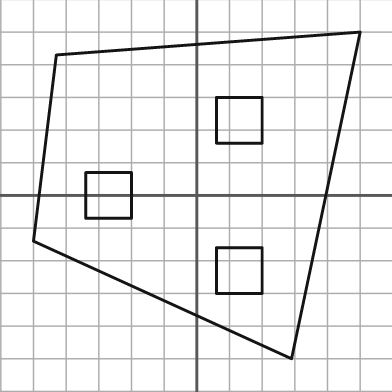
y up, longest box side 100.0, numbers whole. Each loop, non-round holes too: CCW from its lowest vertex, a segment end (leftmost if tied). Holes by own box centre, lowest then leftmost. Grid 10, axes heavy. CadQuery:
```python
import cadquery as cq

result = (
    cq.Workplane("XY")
    .moveTo(29.0, -50.0)
    .lineTo(50.0, 50.0)
    .lineTo(-43.0, 43.0)
    .lineTo(-50.0, -14.0)
    .close()
    .moveTo(6.0, -30.0)
    .lineTo(20.0, -30.0)
    .lineTo(20.0, -16.0)
    .lineTo(6.0, -16.0)
    .close()
    .moveTo(-34.0, -7.0)
    .lineTo(-20.0, -7.0)
    .lineTo(-20.0, 7.0)
    .lineTo(-34.0, 7.0)
    .close()
    .moveTo(6.0, 16.0)
    .lineTo(20.0, 16.0)
    .lineTo(20.0, 30.0)
    .lineTo(6.0, 30.0)
    .close()
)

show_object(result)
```